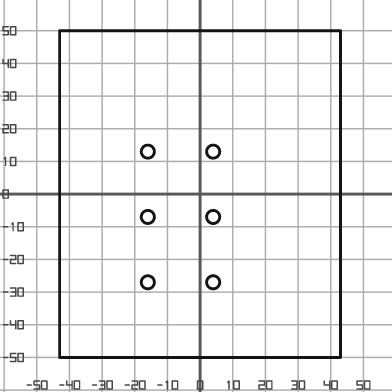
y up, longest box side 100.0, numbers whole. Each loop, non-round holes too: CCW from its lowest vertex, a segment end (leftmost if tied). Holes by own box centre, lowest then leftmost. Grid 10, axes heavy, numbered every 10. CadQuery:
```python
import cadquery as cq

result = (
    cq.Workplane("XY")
    .moveTo(-43.0, -50.0)
    .lineTo(43.0, -50.0)
    .lineTo(43.0, 50.0)
    .lineTo(-43.0, 50.0)
    .close()
    .moveTo(-16.0, -27.0)
    .circle(2.0)
    .moveTo(4.0, -27.0)
    .circle(2.0)
    .moveTo(-16.0, -7.0)
    .circle(2.0)
    .moveTo(4.0, -7.0)
    .circle(2.0)
    .moveTo(-16.0, 13.0)
    .circle(2.0)
    .moveTo(4.0, 13.0)
    .circle(2.0)
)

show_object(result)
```